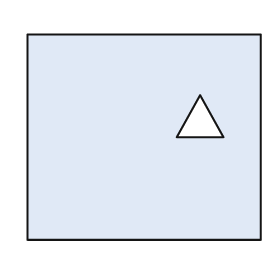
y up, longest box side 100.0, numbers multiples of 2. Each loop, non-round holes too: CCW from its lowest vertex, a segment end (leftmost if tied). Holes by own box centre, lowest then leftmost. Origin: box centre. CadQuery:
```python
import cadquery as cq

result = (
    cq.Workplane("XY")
    .moveTo(-50.0, -44.0)
    .lineTo(50.0, -44.0)
    .lineTo(50.0, 44.0)
    .lineTo(-50.0, 44.0)
    .close()
    .moveTo(14.0, 0.0)
    .lineTo(34.0, 0.0)
    .lineTo(24.0, 18.0)
    .close()
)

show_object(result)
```